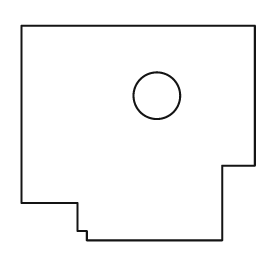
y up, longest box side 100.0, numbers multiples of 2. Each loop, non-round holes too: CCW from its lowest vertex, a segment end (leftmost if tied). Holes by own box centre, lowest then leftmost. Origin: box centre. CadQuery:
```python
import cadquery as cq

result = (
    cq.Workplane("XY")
    .moveTo(-22.0, -46.0)
    .lineTo(36.0, -46.0)
    .lineTo(36.0, -14.0)
    .lineTo(50.0, -14.0)
    .lineTo(50.0, 46.0)
    .lineTo(-50.0, 46.0)
    .lineTo(-50.0, -30.0)
    .lineTo(-26.0, -30.0)
    .lineTo(-26.0, -42.0)
    .lineTo(-22.0, -42.0)
    .close()
    .moveTo(8.0, 16.0)
    .circle(10.0)
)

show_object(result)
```